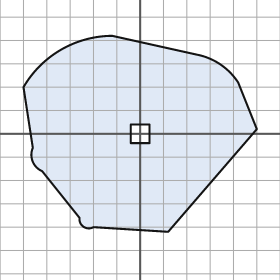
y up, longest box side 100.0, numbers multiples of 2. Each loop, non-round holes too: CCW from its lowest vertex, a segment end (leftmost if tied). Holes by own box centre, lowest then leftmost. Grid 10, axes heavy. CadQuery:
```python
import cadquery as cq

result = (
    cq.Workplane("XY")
    .moveTo(12.0, -42.0)
    .lineTo(50.0, 2.0)
    .lineTo(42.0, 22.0)
    .threePointArc((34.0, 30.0), (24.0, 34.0))
    .lineTo(-12.0, 42.0)
    .threePointArc((-34.0, 36.0), (-50.0, 20.0))
    .lineTo(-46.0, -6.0)
    .threePointArc((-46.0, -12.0), (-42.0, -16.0))
    .lineTo(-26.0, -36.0)
    .threePointArc((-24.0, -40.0), (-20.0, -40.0))
    .close()
    .moveTo(-4.0, -4.0)
    .lineTo(4.0, -4.0)
    .lineTo(4.0, 4.0)
    .lineTo(-4.0, 4.0)
    .close()
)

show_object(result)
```